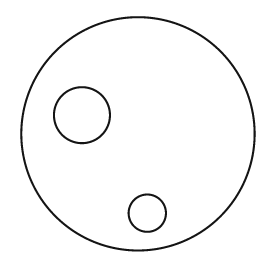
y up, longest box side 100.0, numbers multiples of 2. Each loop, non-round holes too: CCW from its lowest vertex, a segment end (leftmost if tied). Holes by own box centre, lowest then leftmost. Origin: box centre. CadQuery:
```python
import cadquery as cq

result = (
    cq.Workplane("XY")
    .moveTo(0.0, 0.0)
    .circle(50.0)
    .moveTo(4.0, -34.0)
    .circle(8.0)
    .moveTo(-24.0, 8.0)
    .circle(12.0)
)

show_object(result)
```